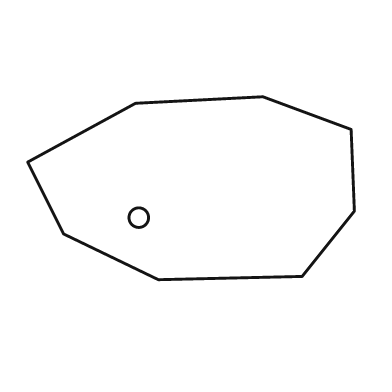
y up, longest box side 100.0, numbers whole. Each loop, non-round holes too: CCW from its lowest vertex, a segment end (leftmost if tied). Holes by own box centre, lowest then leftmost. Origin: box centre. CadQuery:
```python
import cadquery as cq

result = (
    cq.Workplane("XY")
    .moveTo(-10.0, -28.0)
    .lineTo(34.0, -27.0)
    .lineTo(50.0, -7.0)
    .lineTo(49.0, 18.0)
    .lineTo(22.0, 28.0)
    .lineTo(-17.0, 26.0)
    .lineTo(-50.0, 8.0)
    .lineTo(-39.0, -14.0)
    .close()
    .moveTo(-16.0, -9.0)
    .circle(3.0)
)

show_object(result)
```